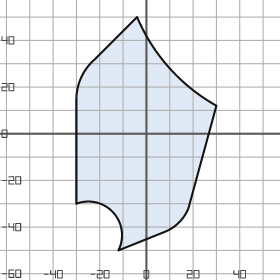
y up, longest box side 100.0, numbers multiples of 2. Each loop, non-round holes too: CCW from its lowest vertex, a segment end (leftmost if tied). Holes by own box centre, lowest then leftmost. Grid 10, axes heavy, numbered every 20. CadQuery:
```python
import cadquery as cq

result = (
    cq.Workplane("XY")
    .moveTo(-12.0, -50.0)
    .lineTo(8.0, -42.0)
    .threePointArc((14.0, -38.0), (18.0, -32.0))
    .lineTo(30.0, 12.0)
    .threePointArc((10.0, 28.0), (-4.0, 50.0))
    .lineTo(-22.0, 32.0)
    .threePointArc((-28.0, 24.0), (-30.0, 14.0))
    .lineTo(-30.0, -30.0)
    .threePointArc((-14.0, -34.0), (-12.0, -50.0))
    .close()
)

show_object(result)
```